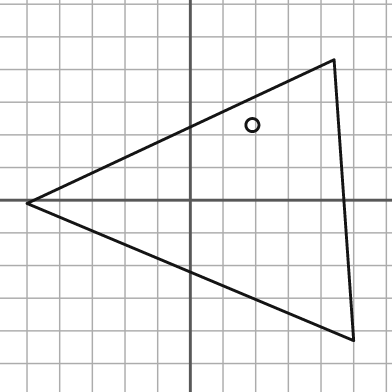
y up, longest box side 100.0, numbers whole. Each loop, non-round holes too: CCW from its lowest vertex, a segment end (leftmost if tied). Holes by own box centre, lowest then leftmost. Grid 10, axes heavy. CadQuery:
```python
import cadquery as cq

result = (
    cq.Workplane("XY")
    .moveTo(50.0, -43.0)
    .lineTo(44.0, 43.0)
    .lineTo(-50.0, -1.0)
    .close()
    .moveTo(19.0, 23.0)
    .circle(2.0)
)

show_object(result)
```